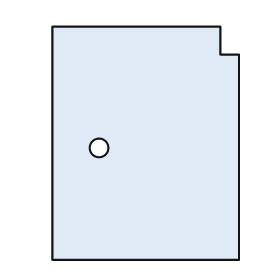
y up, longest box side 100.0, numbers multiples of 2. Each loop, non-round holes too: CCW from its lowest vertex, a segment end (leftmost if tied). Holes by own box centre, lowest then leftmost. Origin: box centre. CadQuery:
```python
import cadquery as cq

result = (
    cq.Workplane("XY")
    .moveTo(-40.0, -50.0)
    .lineTo(40.0, -50.0)
    .lineTo(40.0, 38.0)
    .lineTo(32.0, 38.0)
    .lineTo(32.0, 50.0)
    .lineTo(-40.0, 50.0)
    .close()
    .moveTo(-20.0, -2.0)
    .circle(4.0)
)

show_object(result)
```